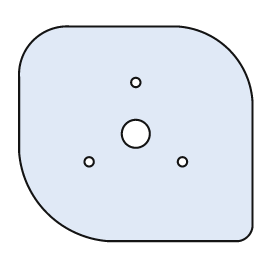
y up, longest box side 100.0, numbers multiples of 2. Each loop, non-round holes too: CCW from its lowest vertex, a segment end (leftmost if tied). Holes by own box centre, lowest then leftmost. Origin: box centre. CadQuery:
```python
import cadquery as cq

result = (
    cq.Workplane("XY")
    .moveTo(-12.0, -46.0)
    .lineTo(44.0, -46.0)
    .threePointArc((48.0, -44.0), (50.0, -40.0))
    .lineTo(50.0, 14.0)
    .threePointArc((40.0, 36.0), (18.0, 46.0))
    .lineTo(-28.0, 46.0)
    .threePointArc((-44.0, 40.0), (-50.0, 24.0))
    .lineTo(-50.0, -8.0)
    .threePointArc((-38.0, -34.0), (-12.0, -46.0))
    .close()
    .moveTo(-20.0, -12.0)
    .circle(2.0)
    .moveTo(20.0, -12.0)
    .circle(2.0)
    .moveTo(0.0, 0.0)
    .circle(6.0)
    .moveTo(0.0, 22.0)
    .circle(2.0)
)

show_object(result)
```